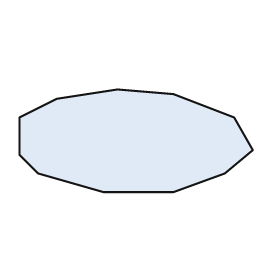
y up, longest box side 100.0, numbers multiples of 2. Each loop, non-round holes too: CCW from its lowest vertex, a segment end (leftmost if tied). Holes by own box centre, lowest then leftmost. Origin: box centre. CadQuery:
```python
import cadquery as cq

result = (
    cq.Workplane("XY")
    .moveTo(-14.0, -22.0)
    .lineTo(16.0, -22.0)
    .lineTo(38.0, -14.0)
    .lineTo(50.0, -4.0)
    .lineTo(42.0, 10.0)
    .lineTo(16.0, 20.0)
    .lineTo(-8.0, 22.0)
    .lineTo(-34.0, 18.0)
    .lineTo(-50.0, 10.0)
    .lineTo(-50.0, -6.0)
    .lineTo(-42.0, -14.0)
    .close()
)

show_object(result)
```